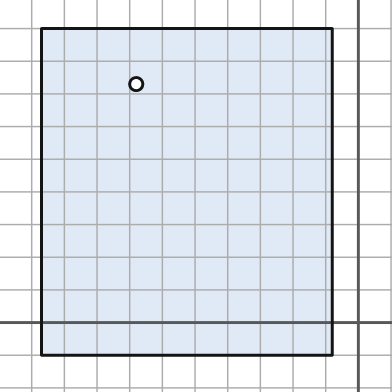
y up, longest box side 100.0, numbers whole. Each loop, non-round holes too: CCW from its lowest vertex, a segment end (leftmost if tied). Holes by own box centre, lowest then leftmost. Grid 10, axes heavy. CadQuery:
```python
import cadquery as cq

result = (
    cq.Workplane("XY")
    .moveTo(-97.0, -10.0)
    .lineTo(-8.0, -10.0)
    .lineTo(-8.0, 90.0)
    .lineTo(-97.0, 90.0)
    .close()
    .moveTo(-68.0, 73.0)
    .circle(2.0)
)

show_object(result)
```